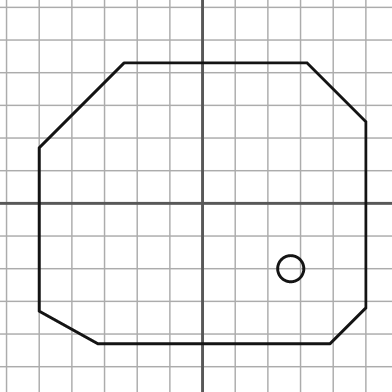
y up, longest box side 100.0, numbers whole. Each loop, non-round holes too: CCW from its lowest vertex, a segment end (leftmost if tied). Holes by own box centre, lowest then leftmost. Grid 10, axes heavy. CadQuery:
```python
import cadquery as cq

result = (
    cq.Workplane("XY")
    .moveTo(-32.0, -43.0)
    .lineTo(39.0, -43.0)
    .lineTo(50.0, -32.0)
    .lineTo(50.0, 25.0)
    .lineTo(32.0, 43.0)
    .lineTo(-24.0, 43.0)
    .lineTo(-50.0, 17.0)
    .lineTo(-50.0, -33.0)
    .close()
    .moveTo(27.0, -20.0)
    .circle(4.0)
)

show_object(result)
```